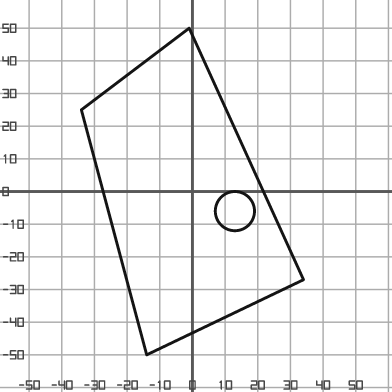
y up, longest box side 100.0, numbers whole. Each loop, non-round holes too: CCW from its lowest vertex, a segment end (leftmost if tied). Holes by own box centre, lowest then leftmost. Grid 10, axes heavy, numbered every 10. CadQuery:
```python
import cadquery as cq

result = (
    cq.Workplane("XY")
    .moveTo(-14.0, -50.0)
    .lineTo(34.0, -27.0)
    .lineTo(-1.0, 50.0)
    .lineTo(-34.0, 25.0)
    .close()
    .moveTo(13.0, -6.0)
    .circle(6.0)
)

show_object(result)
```